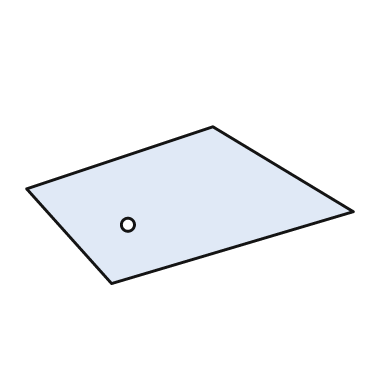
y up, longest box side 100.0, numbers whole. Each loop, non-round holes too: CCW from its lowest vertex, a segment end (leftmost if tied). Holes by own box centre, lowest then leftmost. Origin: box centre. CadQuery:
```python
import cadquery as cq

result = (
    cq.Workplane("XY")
    .moveTo(-24.0, -24.0)
    .lineTo(50.0, -2.0)
    .lineTo(7.0, 24.0)
    .lineTo(-50.0, 5.0)
    .close()
    .moveTo(-19.0, -6.0)
    .circle(2.0)
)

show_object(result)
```